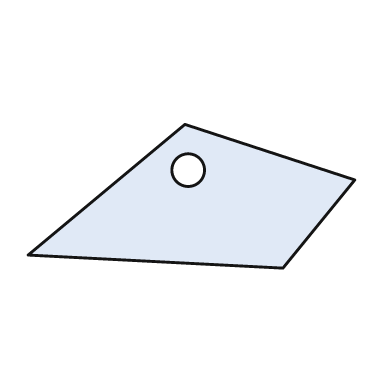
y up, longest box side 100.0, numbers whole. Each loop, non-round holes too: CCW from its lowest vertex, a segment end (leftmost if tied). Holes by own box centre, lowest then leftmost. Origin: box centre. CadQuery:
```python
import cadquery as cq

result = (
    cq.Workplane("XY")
    .moveTo(28.0, -22.0)
    .lineTo(50.0, 5.0)
    .lineTo(-2.0, 22.0)
    .lineTo(-50.0, -18.0)
    .close()
    .moveTo(-1.0, 8.0)
    .circle(5.0)
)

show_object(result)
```